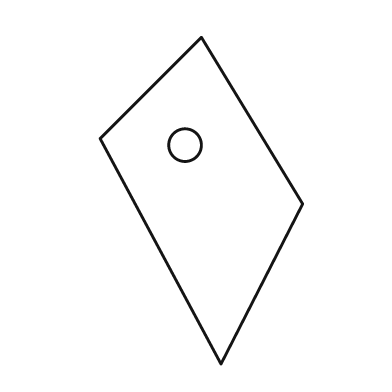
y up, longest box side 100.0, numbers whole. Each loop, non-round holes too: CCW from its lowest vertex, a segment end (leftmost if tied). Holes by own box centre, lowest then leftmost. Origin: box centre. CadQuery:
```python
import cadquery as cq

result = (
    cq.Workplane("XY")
    .moveTo(6.0, -50.0)
    .lineTo(31.0, -1.0)
    .lineTo(0.0, 50.0)
    .lineTo(-31.0, 19.0)
    .close()
    .moveTo(-5.0, 17.0)
    .circle(5.0)
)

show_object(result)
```